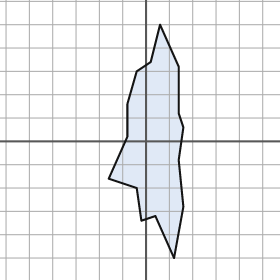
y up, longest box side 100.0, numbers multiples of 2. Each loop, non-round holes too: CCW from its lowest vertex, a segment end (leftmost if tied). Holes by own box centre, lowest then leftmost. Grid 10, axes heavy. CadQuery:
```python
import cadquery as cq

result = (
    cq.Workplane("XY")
    .moveTo(12.0, -50.0)
    .lineTo(16.0, -28.0)
    .lineTo(14.0, -8.0)
    .lineTo(16.0, 6.0)
    .lineTo(14.0, 12.0)
    .lineTo(14.0, 32.0)
    .lineTo(6.0, 50.0)
    .lineTo(2.0, 34.0)
    .lineTo(-4.0, 30.0)
    .lineTo(-8.0, 16.0)
    .lineTo(-8.0, 2.0)
    .lineTo(-16.0, -16.0)
    .lineTo(-4.0, -20.0)
    .lineTo(-2.0, -34.0)
    .lineTo(4.0, -32.0)
    .close()
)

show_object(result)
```